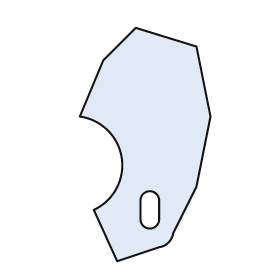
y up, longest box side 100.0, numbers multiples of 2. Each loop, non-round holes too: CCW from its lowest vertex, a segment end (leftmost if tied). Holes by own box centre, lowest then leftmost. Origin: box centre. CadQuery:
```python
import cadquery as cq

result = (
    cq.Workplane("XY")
    .moveTo(-12.0, -50.0)
    .lineTo(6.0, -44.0)
    .threePointArc((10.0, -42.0), (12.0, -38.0))
    .lineTo(22.0, -18.0)
    .lineTo(28.0, 12.0)
    .lineTo(22.0, 42.0)
    .lineTo(-4.0, 50.0)
    .lineTo(-18.0, 36.0)
    .lineTo(-28.0, 12.0)
    .threePointArc((-10.0, -6.0), (-22.0, -28.0))
    .close()
    .moveTo(-2.0, -32.0)
    .threePointArc((2.0, -36.0), (6.0, -32.0))
    .lineTo(6.0, -24.0)
    .threePointArc((2.0, -20.0), (-2.0, -24.0))
    .close()
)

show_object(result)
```